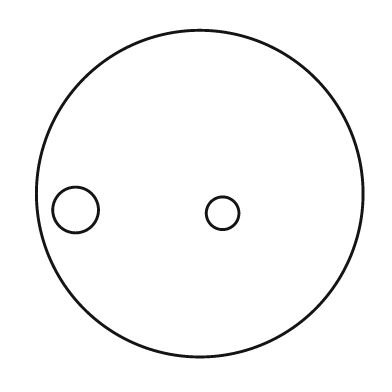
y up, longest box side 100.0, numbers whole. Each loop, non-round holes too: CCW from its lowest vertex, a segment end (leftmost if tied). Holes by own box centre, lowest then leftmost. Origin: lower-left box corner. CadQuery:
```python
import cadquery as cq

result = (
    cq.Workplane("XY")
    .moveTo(50.0, 50.0)
    .circle(50.0)
    .moveTo(57.0, 44.0)
    .circle(5.0)
    .moveTo(12.0, 45.0)
    .circle(7.0)
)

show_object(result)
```